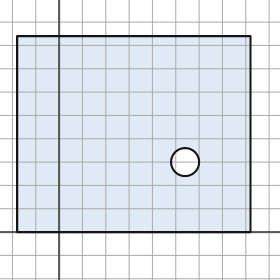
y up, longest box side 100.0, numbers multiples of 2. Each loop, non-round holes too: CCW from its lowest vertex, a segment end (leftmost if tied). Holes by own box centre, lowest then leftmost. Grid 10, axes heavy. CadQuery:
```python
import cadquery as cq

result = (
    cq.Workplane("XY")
    .moveTo(-18.0, 0.0)
    .lineTo(82.0, 0.0)
    .lineTo(82.0, 84.0)
    .lineTo(-18.0, 84.0)
    .close()
    .moveTo(54.0, 30.0)
    .circle(6.0)
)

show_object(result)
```